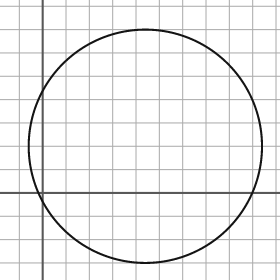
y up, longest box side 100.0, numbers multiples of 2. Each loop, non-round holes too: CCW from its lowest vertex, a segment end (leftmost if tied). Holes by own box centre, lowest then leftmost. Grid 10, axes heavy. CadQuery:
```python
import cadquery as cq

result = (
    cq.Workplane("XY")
    .moveTo(44.0, 20.0)
    .circle(50.0)
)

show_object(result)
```